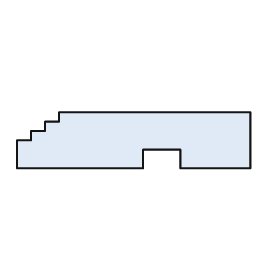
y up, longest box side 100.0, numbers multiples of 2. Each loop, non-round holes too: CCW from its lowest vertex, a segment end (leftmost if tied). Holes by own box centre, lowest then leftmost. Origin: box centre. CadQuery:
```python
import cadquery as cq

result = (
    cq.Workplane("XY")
    .moveTo(-50.0, -12.0)
    .lineTo(4.0, -12.0)
    .lineTo(4.0, -4.0)
    .lineTo(20.0, -4.0)
    .lineTo(20.0, -12.0)
    .lineTo(50.0, -12.0)
    .lineTo(50.0, 12.0)
    .lineTo(-32.0, 12.0)
    .lineTo(-32.0, 8.0)
    .lineTo(-38.0, 8.0)
    .lineTo(-38.0, 4.0)
    .lineTo(-44.0, 4.0)
    .lineTo(-44.0, 0.0)
    .lineTo(-50.0, 0.0)
    .close()
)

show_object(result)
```